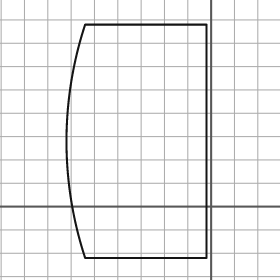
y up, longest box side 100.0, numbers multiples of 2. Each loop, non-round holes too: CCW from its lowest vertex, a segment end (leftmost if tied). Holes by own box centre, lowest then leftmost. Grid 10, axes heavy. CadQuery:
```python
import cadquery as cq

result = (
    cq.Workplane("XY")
    .moveTo(-54.0, -22.0)
    .lineTo(-2.0, -22.0)
    .lineTo(-2.0, 78.0)
    .lineTo(-54.0, 78.0)
    .threePointArc((-62.0, 28.0), (-54.0, -22.0))
    .close()
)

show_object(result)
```